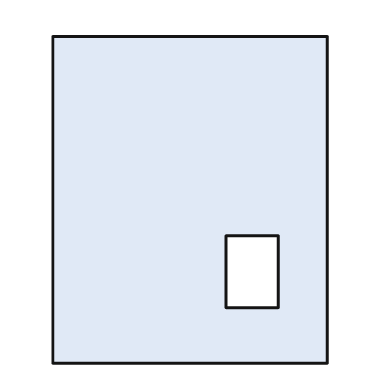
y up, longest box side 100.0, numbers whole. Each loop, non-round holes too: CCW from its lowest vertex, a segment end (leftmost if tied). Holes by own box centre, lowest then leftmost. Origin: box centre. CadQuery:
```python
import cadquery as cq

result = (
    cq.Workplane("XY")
    .moveTo(-42.0, -50.0)
    .lineTo(42.0, -50.0)
    .lineTo(42.0, 50.0)
    .lineTo(-42.0, 50.0)
    .close()
    .moveTo(11.0, -33.0)
    .lineTo(27.0, -33.0)
    .lineTo(27.0, -11.0)
    .lineTo(11.0, -11.0)
    .close()
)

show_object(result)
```